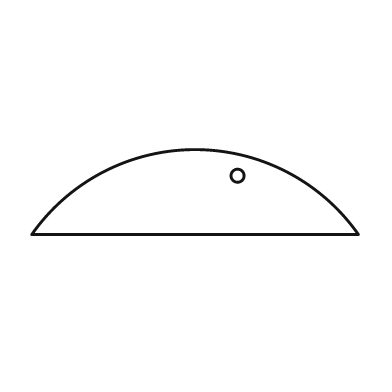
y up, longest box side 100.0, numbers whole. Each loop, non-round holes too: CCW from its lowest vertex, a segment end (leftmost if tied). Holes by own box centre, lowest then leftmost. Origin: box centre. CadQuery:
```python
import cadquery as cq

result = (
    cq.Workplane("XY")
    .moveTo(-50.0, -13.0)
    .lineTo(50.0, -13.0)
    .threePointArc((0.0, 13.0), (-50.0, -13.0))
    .close()
    .moveTo(13.0, 5.0)
    .circle(2.0)
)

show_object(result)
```